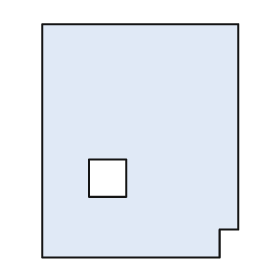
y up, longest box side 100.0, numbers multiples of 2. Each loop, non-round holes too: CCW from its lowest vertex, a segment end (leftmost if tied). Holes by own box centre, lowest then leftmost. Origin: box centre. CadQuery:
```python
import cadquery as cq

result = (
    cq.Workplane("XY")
    .moveTo(-42.0, -50.0)
    .lineTo(34.0, -50.0)
    .lineTo(34.0, -38.0)
    .lineTo(42.0, -38.0)
    .lineTo(42.0, 50.0)
    .lineTo(-42.0, 50.0)
    .close()
    .moveTo(-22.0, -24.0)
    .lineTo(-6.0, -24.0)
    .lineTo(-6.0, -8.0)
    .lineTo(-22.0, -8.0)
    .close()
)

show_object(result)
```